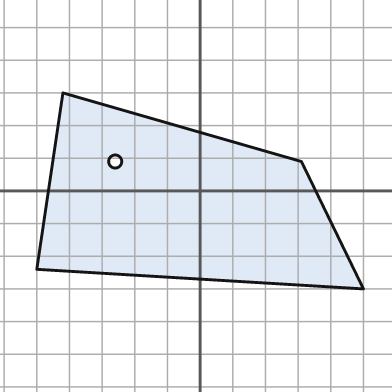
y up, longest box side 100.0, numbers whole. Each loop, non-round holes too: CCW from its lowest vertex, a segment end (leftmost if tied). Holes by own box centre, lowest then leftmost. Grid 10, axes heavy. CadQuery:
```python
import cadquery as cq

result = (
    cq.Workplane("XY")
    .moveTo(50.0, -30.0)
    .lineTo(31.0, 9.0)
    .lineTo(-42.0, 30.0)
    .lineTo(-50.0, -24.0)
    .close()
    .moveTo(-26.0, 9.0)
    .circle(2.0)
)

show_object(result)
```